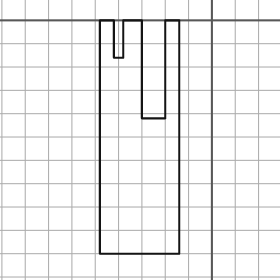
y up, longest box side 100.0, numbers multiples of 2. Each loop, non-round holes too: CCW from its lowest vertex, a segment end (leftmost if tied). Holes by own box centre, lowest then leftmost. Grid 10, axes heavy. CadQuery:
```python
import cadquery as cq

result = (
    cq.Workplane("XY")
    .moveTo(-48.0, -100.0)
    .lineTo(-14.0, -100.0)
    .lineTo(-14.0, 0.0)
    .lineTo(-20.0, 0.0)
    .lineTo(-20.0, -42.0)
    .lineTo(-30.0, -42.0)
    .lineTo(-30.0, 0.0)
    .lineTo(-38.0, 0.0)
    .lineTo(-38.0, -16.0)
    .lineTo(-42.0, -16.0)
    .lineTo(-42.0, 0.0)
    .lineTo(-48.0, 0.0)
    .close()
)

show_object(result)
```